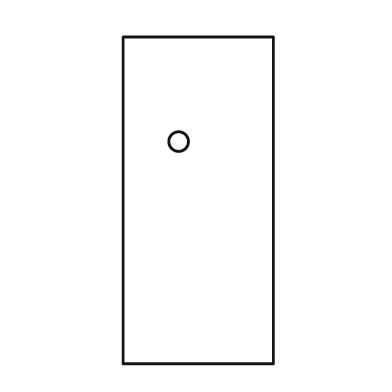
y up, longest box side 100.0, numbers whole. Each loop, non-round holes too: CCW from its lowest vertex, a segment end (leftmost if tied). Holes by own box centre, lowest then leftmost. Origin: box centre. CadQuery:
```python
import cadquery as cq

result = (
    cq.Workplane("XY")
    .moveTo(-23.0, -50.0)
    .lineTo(23.0, -50.0)
    .lineTo(23.0, 50.0)
    .lineTo(-23.0, 50.0)
    .close()
    .moveTo(-6.0, 18.0)
    .circle(3.0)
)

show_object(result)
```